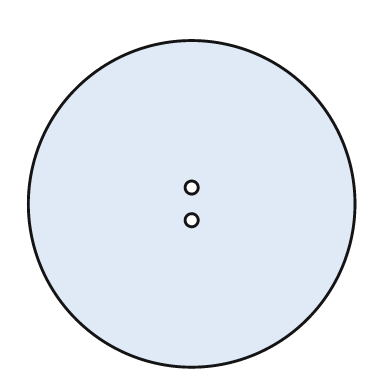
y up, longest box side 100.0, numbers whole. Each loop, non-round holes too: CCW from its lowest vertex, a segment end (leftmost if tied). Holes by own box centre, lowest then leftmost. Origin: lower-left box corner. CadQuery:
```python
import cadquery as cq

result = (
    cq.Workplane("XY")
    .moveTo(50.0, 50.0)
    .circle(50.0)
    .moveTo(50.0, 45.0)
    .circle(2.0)
    .moveTo(50.0, 55.0)
    .circle(2.0)
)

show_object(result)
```